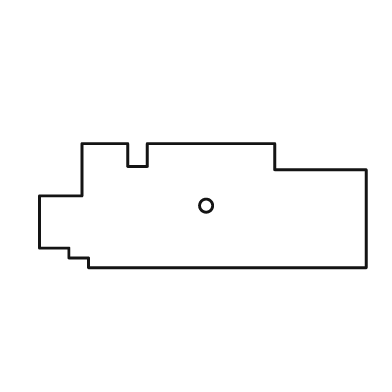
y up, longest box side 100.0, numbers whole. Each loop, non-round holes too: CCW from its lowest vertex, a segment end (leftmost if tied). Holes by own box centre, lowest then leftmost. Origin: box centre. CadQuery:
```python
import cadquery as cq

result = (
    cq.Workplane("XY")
    .moveTo(-35.0, -19.0)
    .lineTo(50.0, -19.0)
    .lineTo(50.0, 11.0)
    .lineTo(22.0, 11.0)
    .lineTo(22.0, 19.0)
    .lineTo(-17.0, 19.0)
    .lineTo(-17.0, 12.0)
    .lineTo(-23.0, 12.0)
    .lineTo(-23.0, 19.0)
    .lineTo(-37.0, 19.0)
    .lineTo(-37.0, 3.0)
    .lineTo(-50.0, 3.0)
    .lineTo(-50.0, -13.0)
    .lineTo(-41.0, -13.0)
    .lineTo(-41.0, -16.0)
    .lineTo(-35.0, -16.0)
    .close()
    .moveTo(1.0, 0.0)
    .circle(2.0)
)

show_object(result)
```